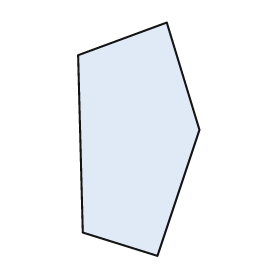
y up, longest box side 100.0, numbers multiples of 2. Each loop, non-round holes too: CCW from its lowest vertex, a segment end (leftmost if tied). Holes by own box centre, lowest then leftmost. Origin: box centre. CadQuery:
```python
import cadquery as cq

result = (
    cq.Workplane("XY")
    .moveTo(8.0, -50.0)
    .lineTo(26.0, 4.0)
    .lineTo(12.0, 50.0)
    .lineTo(-26.0, 36.0)
    .lineTo(-24.0, -40.0)
    .close()
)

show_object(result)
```